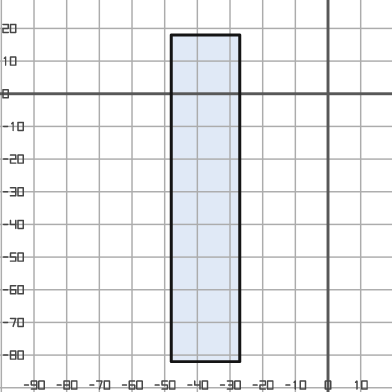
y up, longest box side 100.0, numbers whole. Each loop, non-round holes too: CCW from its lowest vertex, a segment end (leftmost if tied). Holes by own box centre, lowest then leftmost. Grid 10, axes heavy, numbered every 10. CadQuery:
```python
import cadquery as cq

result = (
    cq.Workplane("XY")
    .moveTo(-48.0, -82.0)
    .lineTo(-27.0, -82.0)
    .lineTo(-27.0, 18.0)
    .lineTo(-48.0, 18.0)
    .close()
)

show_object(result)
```